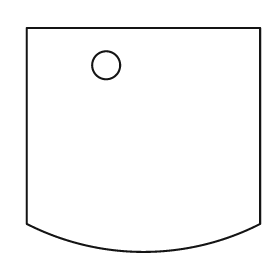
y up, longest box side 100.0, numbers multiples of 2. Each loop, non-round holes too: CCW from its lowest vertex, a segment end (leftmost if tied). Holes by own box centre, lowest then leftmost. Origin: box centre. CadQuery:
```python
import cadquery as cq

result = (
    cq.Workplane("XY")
    .moveTo(-50.0, -36.0)
    .threePointArc((0.0, -48.0), (50.0, -36.0))
    .lineTo(50.0, 48.0)
    .lineTo(-50.0, 48.0)
    .close()
    .moveTo(-16.0, 32.0)
    .circle(6.0)
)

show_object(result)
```